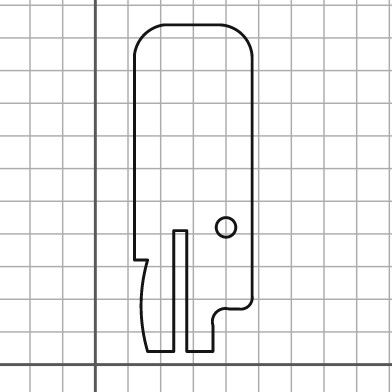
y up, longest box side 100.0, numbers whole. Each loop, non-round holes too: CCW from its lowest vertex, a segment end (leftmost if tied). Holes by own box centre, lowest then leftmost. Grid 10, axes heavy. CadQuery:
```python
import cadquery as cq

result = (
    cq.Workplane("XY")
    .moveTo(16.0, 4.0)
    .lineTo(24.0, 4.0)
    .lineTo(24.0, 41.0)
    .lineTo(28.0, 41.0)
    .lineTo(28.0, 4.0)
    .lineTo(36.0, 4.0)
    .lineTo(36.0, 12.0)
    .threePointArc((37.0, 16.0), (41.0, 17.0))
    .lineTo(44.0, 17.0)
    .threePointArc((47.0, 18.0), (48.0, 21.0))
    .lineTo(48.0, 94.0)
    .threePointArc((45.0, 101.0), (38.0, 104.0))
    .lineTo(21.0, 104.0)
    .threePointArc((15.0, 101.0), (12.0, 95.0))
    .lineTo(12.0, 32.0)
    .lineTo(16.0, 32.0)
    .threePointArc((14.0, 18.0), (16.0, 4.0))
    .close()
    .moveTo(40.0, 42.0)
    .circle(3.0)
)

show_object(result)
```